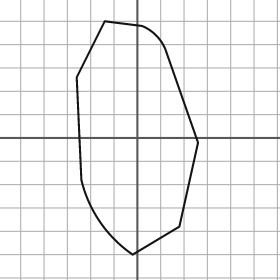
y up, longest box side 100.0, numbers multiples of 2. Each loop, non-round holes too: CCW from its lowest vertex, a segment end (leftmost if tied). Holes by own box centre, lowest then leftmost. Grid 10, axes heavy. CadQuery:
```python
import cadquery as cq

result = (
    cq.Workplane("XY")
    .moveTo(-2.0, -50.0)
    .lineTo(18.0, -38.0)
    .lineTo(26.0, -2.0)
    .lineTo(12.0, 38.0)
    .threePointArc((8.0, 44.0), (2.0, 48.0))
    .lineTo(-14.0, 50.0)
    .lineTo(-26.0, 26.0)
    .lineTo(-24.0, -18.0)
    .threePointArc((-16.0, -36.0), (-2.0, -50.0))
    .close()
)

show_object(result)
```